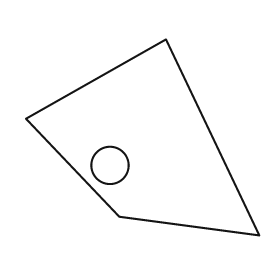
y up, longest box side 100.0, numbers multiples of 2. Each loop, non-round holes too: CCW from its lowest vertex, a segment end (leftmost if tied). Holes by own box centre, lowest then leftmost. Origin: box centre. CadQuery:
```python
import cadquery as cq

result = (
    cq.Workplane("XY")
    .moveTo(50.0, -42.0)
    .lineTo(10.0, 42.0)
    .lineTo(-50.0, 8.0)
    .lineTo(-10.0, -34.0)
    .close()
    .moveTo(-14.0, -12.0)
    .circle(8.0)
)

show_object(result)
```